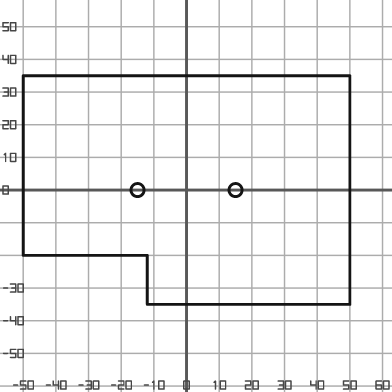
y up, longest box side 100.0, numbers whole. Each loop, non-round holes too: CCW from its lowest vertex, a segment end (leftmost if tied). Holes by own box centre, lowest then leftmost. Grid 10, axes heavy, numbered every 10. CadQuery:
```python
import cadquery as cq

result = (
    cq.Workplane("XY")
    .moveTo(-12.0, -35.0)
    .lineTo(50.0, -35.0)
    .lineTo(50.0, 35.0)
    .lineTo(-50.0, 35.0)
    .lineTo(-50.0, -20.0)
    .lineTo(-12.0, -20.0)
    .close()
    .moveTo(-15.0, 0.0)
    .circle(2.0)
    .moveTo(15.0, 0.0)
    .circle(2.0)
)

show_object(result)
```